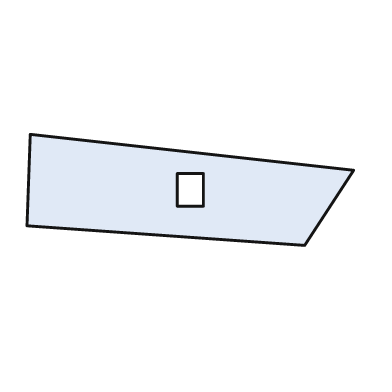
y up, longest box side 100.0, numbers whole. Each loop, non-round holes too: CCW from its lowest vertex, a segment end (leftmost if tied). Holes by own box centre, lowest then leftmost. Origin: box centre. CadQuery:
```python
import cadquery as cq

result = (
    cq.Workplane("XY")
    .moveTo(35.0, -17.0)
    .lineTo(50.0, 6.0)
    .lineTo(-49.0, 17.0)
    .lineTo(-50.0, -11.0)
    .close()
    .moveTo(-4.0, -5.0)
    .lineTo(4.0, -5.0)
    .lineTo(4.0, 5.0)
    .lineTo(-4.0, 5.0)
    .close()
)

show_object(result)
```